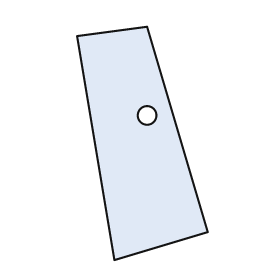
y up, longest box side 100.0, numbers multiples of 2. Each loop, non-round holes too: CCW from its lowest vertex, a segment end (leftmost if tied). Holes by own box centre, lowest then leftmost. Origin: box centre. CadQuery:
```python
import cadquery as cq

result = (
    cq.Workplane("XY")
    .moveTo(-12.0, -50.0)
    .lineTo(28.0, -38.0)
    .lineTo(2.0, 50.0)
    .lineTo(-28.0, 46.0)
    .close()
    .moveTo(2.0, 12.0)
    .circle(4.0)
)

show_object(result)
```